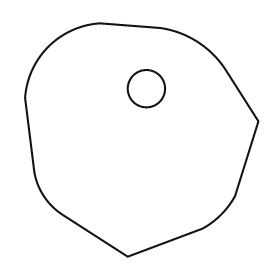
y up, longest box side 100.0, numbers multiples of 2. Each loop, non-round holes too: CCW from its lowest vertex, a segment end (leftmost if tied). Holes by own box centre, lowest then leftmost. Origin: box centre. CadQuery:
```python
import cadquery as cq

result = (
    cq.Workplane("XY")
    .moveTo(-6.0, -50.0)
    .lineTo(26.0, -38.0)
    .threePointArc((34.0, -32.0), (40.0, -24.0))
    .lineTo(50.0, 8.0)
    .lineTo(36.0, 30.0)
    .threePointArc((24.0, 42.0), (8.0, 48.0))
    .lineTo(-18.0, 50.0)
    .threePointArc((-40.0, 40.0), (-50.0, 18.0))
    .lineTo(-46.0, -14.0)
    .threePointArc((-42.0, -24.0), (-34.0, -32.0))
    .close()
    .moveTo(2.0, 22.0)
    .circle(8.0)
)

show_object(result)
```